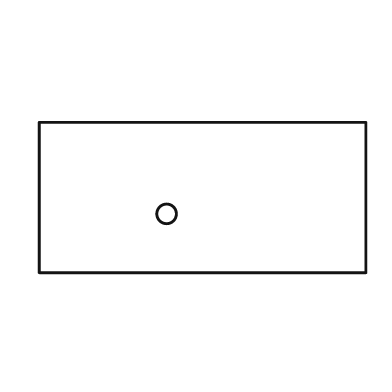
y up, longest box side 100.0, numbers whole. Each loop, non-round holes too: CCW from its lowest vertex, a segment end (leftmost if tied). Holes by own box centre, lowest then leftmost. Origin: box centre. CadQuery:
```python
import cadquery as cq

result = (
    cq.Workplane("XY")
    .moveTo(-50.0, -23.0)
    .lineTo(50.0, -23.0)
    .lineTo(50.0, 23.0)
    .lineTo(-50.0, 23.0)
    .close()
    .moveTo(-11.0, -5.0)
    .circle(3.0)
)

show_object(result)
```